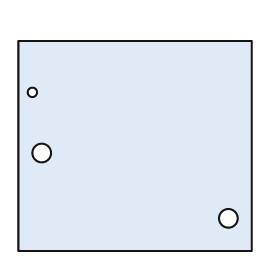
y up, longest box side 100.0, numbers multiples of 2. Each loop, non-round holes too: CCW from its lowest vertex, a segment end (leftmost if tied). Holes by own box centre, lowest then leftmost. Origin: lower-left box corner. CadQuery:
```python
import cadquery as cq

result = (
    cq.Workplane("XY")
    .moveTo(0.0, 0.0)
    .lineTo(100.0, 0.0)
    .lineTo(100.0, 90.0)
    .lineTo(0.0, 90.0)
    .close()
    .moveTo(90.0, 14.0)
    .circle(4.0)
    .moveTo(10.0, 42.0)
    .circle(4.0)
    .moveTo(6.0, 68.0)
    .circle(2.0)
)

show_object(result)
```